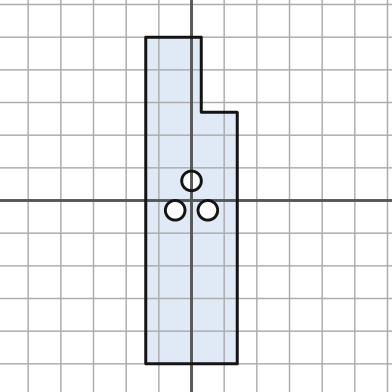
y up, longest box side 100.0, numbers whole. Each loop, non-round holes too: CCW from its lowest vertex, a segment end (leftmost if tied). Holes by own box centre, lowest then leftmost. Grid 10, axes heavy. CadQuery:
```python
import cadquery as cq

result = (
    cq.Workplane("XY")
    .moveTo(-14.0, -50.0)
    .lineTo(14.0, -50.0)
    .lineTo(14.0, 27.0)
    .lineTo(3.0, 27.0)
    .lineTo(3.0, 50.0)
    .lineTo(-14.0, 50.0)
    .close()
    .moveTo(-5.0, -3.0)
    .circle(3.0)
    .moveTo(5.0, -3.0)
    .circle(3.0)
    .moveTo(0.0, 6.0)
    .circle(3.0)
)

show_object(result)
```